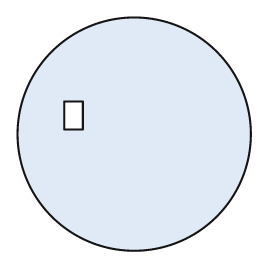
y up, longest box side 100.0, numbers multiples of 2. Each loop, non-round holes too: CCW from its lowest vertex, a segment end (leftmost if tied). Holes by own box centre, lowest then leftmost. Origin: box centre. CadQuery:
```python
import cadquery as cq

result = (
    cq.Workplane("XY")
    .moveTo(0.0, 0.0)
    .circle(50.0)
    .moveTo(-30.0, 2.0)
    .lineTo(-22.0, 2.0)
    .lineTo(-22.0, 14.0)
    .lineTo(-30.0, 14.0)
    .close()
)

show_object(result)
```